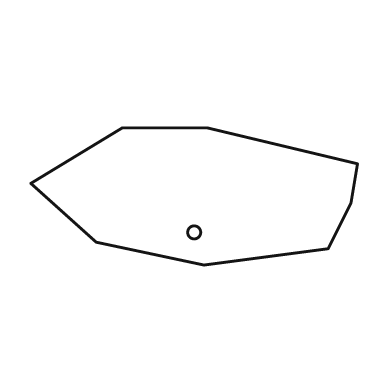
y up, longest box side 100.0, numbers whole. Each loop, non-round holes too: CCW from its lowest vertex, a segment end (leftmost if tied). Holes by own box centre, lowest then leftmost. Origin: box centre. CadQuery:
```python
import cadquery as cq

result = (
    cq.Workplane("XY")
    .moveTo(3.0, -21.0)
    .lineTo(41.0, -16.0)
    .lineTo(48.0, -2.0)
    .lineTo(50.0, 10.0)
    .lineTo(4.0, 21.0)
    .lineTo(-22.0, 21.0)
    .lineTo(-50.0, 4.0)
    .lineTo(-30.0, -14.0)
    .close()
    .moveTo(0.0, -11.0)
    .circle(2.0)
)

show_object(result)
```